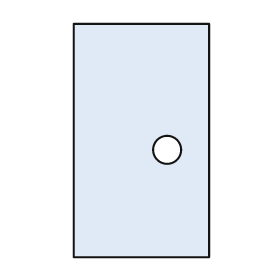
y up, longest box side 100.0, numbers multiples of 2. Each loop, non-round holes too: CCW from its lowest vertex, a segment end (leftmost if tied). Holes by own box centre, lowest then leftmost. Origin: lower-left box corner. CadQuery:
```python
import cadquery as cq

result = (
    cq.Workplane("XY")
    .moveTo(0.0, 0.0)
    .lineTo(58.0, 0.0)
    .lineTo(58.0, 100.0)
    .lineTo(0.0, 100.0)
    .close()
    .moveTo(40.0, 46.0)
    .circle(6.0)
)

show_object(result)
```